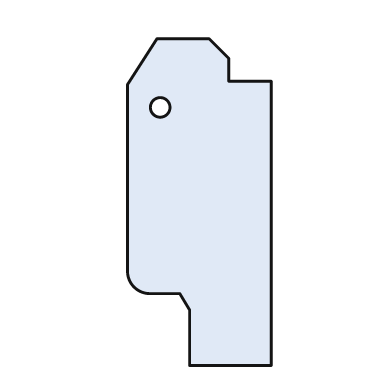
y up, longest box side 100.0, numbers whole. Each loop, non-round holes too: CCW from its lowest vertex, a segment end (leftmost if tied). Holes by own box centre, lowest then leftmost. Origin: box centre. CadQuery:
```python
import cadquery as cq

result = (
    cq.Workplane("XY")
    .moveTo(-3.0, -50.0)
    .lineTo(22.0, -50.0)
    .lineTo(22.0, 37.0)
    .lineTo(9.0, 37.0)
    .lineTo(9.0, 44.0)
    .lineTo(3.0, 50.0)
    .lineTo(-13.0, 50.0)
    .lineTo(-22.0, 36.0)
    .lineTo(-22.0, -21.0)
    .threePointArc((-20.0, -26.0), (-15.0, -28.0))
    .lineTo(-6.0, -28.0)
    .lineTo(-3.0, -33.0)
    .close()
    .moveTo(-12.0, 29.0)
    .circle(3.0)
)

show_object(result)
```